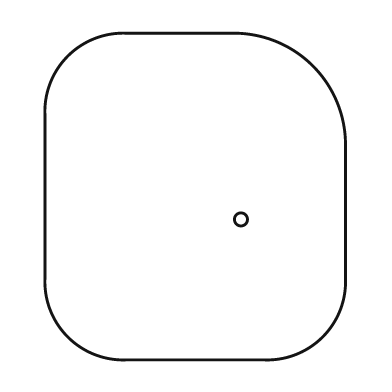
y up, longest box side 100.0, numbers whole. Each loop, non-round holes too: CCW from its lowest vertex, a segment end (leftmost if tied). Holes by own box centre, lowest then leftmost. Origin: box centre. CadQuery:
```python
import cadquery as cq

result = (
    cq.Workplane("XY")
    .moveTo(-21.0, -50.0)
    .lineTo(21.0, -50.0)
    .threePointArc((39.0, -43.0), (46.0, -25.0))
    .lineTo(46.0, 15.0)
    .threePointArc((36.0, 40.0), (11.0, 50.0))
    .lineTo(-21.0, 50.0)
    .threePointArc((-39.0, 43.0), (-46.0, 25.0))
    .lineTo(-46.0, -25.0)
    .threePointArc((-39.0, -43.0), (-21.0, -50.0))
    .close()
    .moveTo(14.0, -7.0)
    .circle(2.0)
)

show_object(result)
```